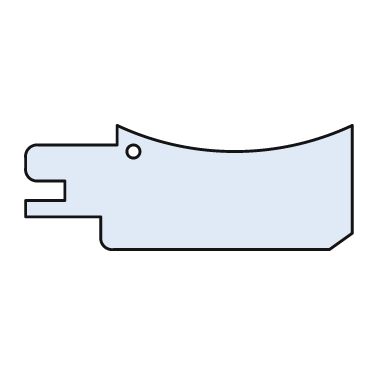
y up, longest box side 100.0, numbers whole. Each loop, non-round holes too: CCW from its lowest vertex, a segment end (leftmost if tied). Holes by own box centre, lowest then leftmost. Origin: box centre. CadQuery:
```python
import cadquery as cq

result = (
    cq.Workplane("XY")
    .moveTo(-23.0, -19.0)
    .lineTo(43.0, -19.0)
    .lineTo(50.0, -14.0)
    .lineTo(50.0, 19.0)
    .threePointArc((14.0, 11.0), (-22.0, 19.0))
    .lineTo(-22.0, 13.0)
    .lineTo(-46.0, 13.0)
    .threePointArc((-49.0, 12.0), (-50.0, 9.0))
    .lineTo(-50.0, 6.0)
    .threePointArc((-49.0, 3.0), (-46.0, 2.0))
    .lineTo(-38.0, 2.0)
    .lineTo(-38.0, -4.0)
    .lineTo(-50.0, -4.0)
    .lineTo(-50.0, -9.0)
    .lineTo(-27.0, -9.0)
    .lineTo(-27.0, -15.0)
    .threePointArc((-26.0, -18.0), (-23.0, -19.0))
    .close()
    .moveTo(-17.0, 11.0)
    .circle(2.0)
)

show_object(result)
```